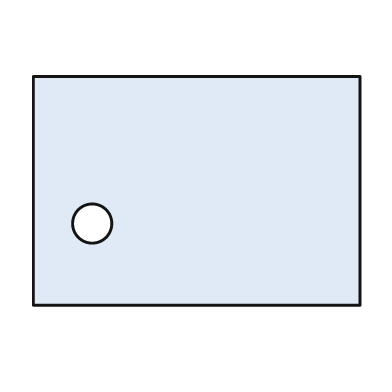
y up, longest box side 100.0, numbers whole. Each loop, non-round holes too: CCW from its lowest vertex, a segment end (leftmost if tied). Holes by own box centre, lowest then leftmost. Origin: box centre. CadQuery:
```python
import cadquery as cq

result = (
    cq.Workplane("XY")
    .moveTo(-50.0, -35.0)
    .lineTo(50.0, -35.0)
    .lineTo(50.0, 35.0)
    .lineTo(-50.0, 35.0)
    .close()
    .moveTo(-32.0, -10.0)
    .circle(6.0)
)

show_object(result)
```